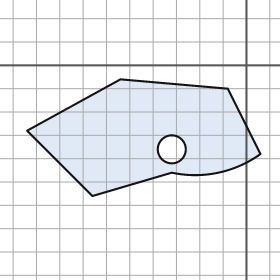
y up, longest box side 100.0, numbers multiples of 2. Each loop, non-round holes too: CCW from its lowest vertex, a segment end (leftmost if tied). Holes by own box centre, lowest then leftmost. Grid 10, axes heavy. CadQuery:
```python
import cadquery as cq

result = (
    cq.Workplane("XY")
    .moveTo(-66.0, -56.0)
    .lineTo(-32.0, -46.0)
    .threePointArc((-12.0, -46.0), (6.0, -38.0))
    .lineTo(-8.0, -10.0)
    .lineTo(-54.0, -6.0)
    .lineTo(-94.0, -28.0)
    .close()
    .moveTo(-32.0, -36.0)
    .circle(6.0)
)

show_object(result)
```